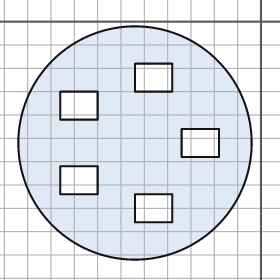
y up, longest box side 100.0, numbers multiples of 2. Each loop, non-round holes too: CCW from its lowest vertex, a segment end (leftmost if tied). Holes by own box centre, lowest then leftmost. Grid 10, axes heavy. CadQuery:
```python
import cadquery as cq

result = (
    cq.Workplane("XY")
    .moveTo(-54.0, -52.0)
    .circle(50.0)
    .moveTo(-54.0, -86.0)
    .lineTo(-38.0, -86.0)
    .lineTo(-38.0, -74.0)
    .lineTo(-54.0, -74.0)
    .close()
    .moveTo(-86.0, -74.0)
    .lineTo(-70.0, -74.0)
    .lineTo(-70.0, -62.0)
    .lineTo(-86.0, -62.0)
    .close()
    .moveTo(-34.0, -58.0)
    .lineTo(-18.0, -58.0)
    .lineTo(-18.0, -46.0)
    .lineTo(-34.0, -46.0)
    .close()
    .moveTo(-86.0, -42.0)
    .lineTo(-70.0, -42.0)
    .lineTo(-70.0, -30.0)
    .lineTo(-86.0, -30.0)
    .close()
    .moveTo(-54.0, -30.0)
    .lineTo(-38.0, -30.0)
    .lineTo(-38.0, -18.0)
    .lineTo(-54.0, -18.0)
    .close()
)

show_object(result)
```